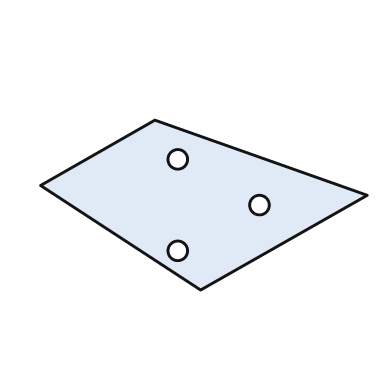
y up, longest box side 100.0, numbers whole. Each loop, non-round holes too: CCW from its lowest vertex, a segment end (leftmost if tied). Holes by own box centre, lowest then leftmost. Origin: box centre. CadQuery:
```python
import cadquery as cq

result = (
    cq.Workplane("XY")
    .moveTo(-1.0, -26.0)
    .lineTo(50.0, 3.0)
    .lineTo(-15.0, 26.0)
    .lineTo(-50.0, 6.0)
    .close()
    .moveTo(-8.0, -14.0)
    .circle(3.0)
    .moveTo(17.0, 0.0)
    .circle(3.0)
    .moveTo(-8.0, 14.0)
    .circle(3.0)
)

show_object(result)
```